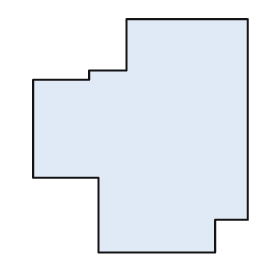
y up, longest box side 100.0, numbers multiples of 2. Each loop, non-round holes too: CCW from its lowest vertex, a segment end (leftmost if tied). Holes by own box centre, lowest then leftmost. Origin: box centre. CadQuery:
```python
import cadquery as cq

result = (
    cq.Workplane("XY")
    .moveTo(-18.0, -50.0)
    .lineTo(32.0, -50.0)
    .lineTo(32.0, -36.0)
    .lineTo(46.0, -36.0)
    .lineTo(46.0, 50.0)
    .lineTo(-6.0, 50.0)
    .lineTo(-6.0, 28.0)
    .lineTo(-22.0, 28.0)
    .lineTo(-22.0, 24.0)
    .lineTo(-46.0, 24.0)
    .lineTo(-46.0, -18.0)
    .lineTo(-18.0, -18.0)
    .close()
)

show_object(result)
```